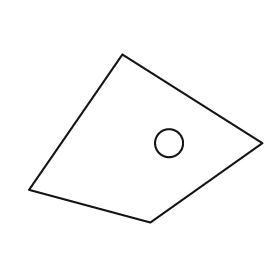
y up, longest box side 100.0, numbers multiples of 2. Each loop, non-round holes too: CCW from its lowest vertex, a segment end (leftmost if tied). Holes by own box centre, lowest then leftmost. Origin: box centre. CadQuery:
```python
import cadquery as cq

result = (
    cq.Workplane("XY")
    .moveTo(2.0, -36.0)
    .lineTo(50.0, -2.0)
    .lineTo(-10.0, 36.0)
    .lineTo(-50.0, -22.0)
    .close()
    .moveTo(10.0, -2.0)
    .circle(6.0)
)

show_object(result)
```